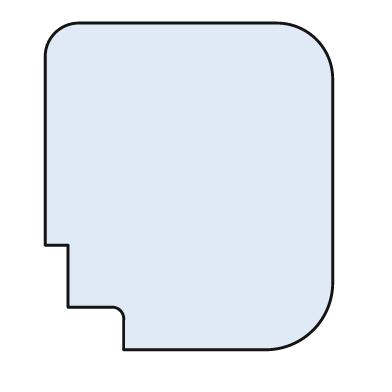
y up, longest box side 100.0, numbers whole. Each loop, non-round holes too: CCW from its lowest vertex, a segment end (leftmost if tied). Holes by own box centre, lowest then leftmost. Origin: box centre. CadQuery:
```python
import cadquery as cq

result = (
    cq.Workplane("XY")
    .moveTo(-20.0, -50.0)
    .lineTo(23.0, -50.0)
    .threePointArc((38.0, -44.0), (44.0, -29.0))
    .lineTo(44.0, 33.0)
    .threePointArc((39.0, 45.0), (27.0, 50.0))
    .lineTo(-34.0, 50.0)
    .threePointArc((-41.0, 47.0), (-44.0, 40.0))
    .lineTo(-44.0, -18.0)
    .lineTo(-37.0, -18.0)
    .lineTo(-37.0, -37.0)
    .lineTo(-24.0, -37.0)
    .threePointArc((-21.0, -38.0), (-20.0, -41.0))
    .close()
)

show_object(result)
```